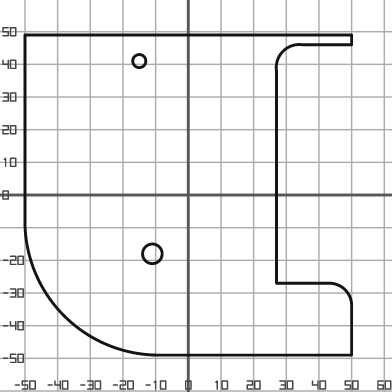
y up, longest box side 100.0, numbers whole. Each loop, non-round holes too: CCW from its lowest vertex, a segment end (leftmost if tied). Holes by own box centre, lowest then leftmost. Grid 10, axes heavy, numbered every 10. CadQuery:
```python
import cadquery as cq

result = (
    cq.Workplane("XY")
    .moveTo(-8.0, -49.0)
    .lineTo(50.0, -49.0)
    .lineTo(50.0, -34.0)
    .threePointArc((48.0, -29.0), (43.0, -27.0))
    .lineTo(27.0, -27.0)
    .lineTo(27.0, 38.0)
    .threePointArc((29.0, 44.0), (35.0, 46.0))
    .lineTo(50.0, 46.0)
    .lineTo(50.0, 49.0)
    .lineTo(-50.0, 49.0)
    .lineTo(-50.0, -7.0)
    .threePointArc((-38.0, -37.0), (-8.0, -49.0))
    .close()
    .moveTo(-11.0, -18.0)
    .circle(3.0)
    .moveTo(-15.0, 41.0)
    .circle(2.0)
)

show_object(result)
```